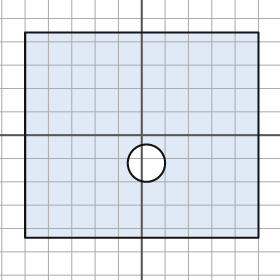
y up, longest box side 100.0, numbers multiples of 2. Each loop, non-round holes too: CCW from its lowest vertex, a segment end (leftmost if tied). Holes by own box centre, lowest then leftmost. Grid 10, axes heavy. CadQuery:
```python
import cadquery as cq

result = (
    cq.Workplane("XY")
    .moveTo(-50.0, -44.0)
    .lineTo(50.0, -44.0)
    .lineTo(50.0, 44.0)
    .lineTo(-50.0, 44.0)
    .close()
    .moveTo(2.0, -12.0)
    .circle(8.0)
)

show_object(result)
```